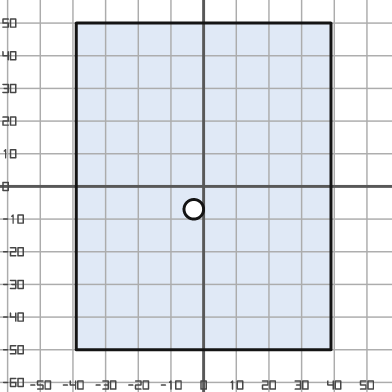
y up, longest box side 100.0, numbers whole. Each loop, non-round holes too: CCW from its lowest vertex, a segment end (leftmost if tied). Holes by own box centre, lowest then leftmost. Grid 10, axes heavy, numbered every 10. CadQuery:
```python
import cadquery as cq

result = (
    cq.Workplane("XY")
    .moveTo(-39.0, -50.0)
    .lineTo(39.0, -50.0)
    .lineTo(39.0, 50.0)
    .lineTo(-39.0, 50.0)
    .close()
    .moveTo(-3.0, -7.0)
    .circle(3.0)
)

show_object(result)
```